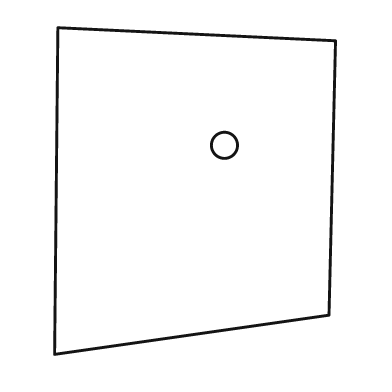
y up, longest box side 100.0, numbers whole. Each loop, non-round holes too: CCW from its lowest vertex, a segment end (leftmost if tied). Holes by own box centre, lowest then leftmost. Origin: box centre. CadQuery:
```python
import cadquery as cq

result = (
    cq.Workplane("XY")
    .moveTo(-43.0, -50.0)
    .lineTo(41.0, -38.0)
    .lineTo(43.0, 46.0)
    .lineTo(-42.0, 50.0)
    .close()
    .moveTo(9.0, 14.0)
    .circle(4.0)
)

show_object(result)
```